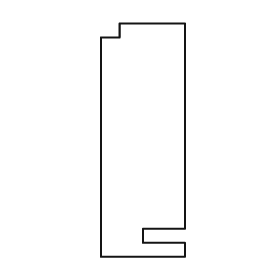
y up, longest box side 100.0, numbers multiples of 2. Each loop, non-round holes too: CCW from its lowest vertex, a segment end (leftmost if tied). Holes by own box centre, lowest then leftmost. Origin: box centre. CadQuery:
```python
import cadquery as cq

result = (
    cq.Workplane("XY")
    .moveTo(-18.0, -50.0)
    .lineTo(18.0, -50.0)
    .lineTo(18.0, -44.0)
    .lineTo(0.0, -44.0)
    .lineTo(0.0, -38.0)
    .lineTo(18.0, -38.0)
    .lineTo(18.0, 50.0)
    .lineTo(-10.0, 50.0)
    .lineTo(-10.0, 44.0)
    .lineTo(-18.0, 44.0)
    .close()
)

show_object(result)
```